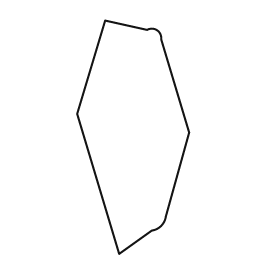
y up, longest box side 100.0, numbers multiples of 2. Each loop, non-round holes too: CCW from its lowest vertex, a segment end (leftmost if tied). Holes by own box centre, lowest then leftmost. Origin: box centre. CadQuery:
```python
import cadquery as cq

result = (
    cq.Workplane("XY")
    .moveTo(-6.0, -50.0)
    .lineTo(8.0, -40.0)
    .threePointArc((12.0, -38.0), (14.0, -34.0))
    .lineTo(24.0, 2.0)
    .lineTo(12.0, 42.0)
    .threePointArc((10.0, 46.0), (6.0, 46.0))
    .lineTo(-12.0, 50.0)
    .lineTo(-24.0, 10.0)
    .close()
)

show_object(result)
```